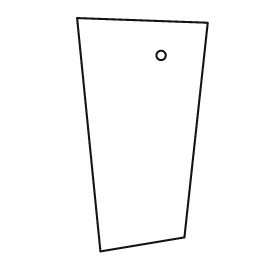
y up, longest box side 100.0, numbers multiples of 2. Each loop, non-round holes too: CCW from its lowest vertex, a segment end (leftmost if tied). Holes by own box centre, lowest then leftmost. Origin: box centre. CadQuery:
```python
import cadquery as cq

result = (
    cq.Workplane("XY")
    .moveTo(-18.0, -50.0)
    .lineTo(18.0, -44.0)
    .lineTo(28.0, 48.0)
    .lineTo(-28.0, 50.0)
    .close()
    .moveTo(8.0, 34.0)
    .circle(2.0)
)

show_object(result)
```